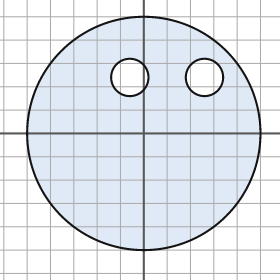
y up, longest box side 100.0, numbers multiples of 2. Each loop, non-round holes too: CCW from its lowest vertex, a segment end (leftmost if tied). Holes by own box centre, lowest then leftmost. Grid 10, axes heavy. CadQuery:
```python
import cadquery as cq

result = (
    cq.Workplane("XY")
    .moveTo(0.0, 0.0)
    .circle(50.0)
    .moveTo(-6.0, 24.0)
    .circle(8.0)
    .moveTo(26.0, 24.0)
    .circle(8.0)
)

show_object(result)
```